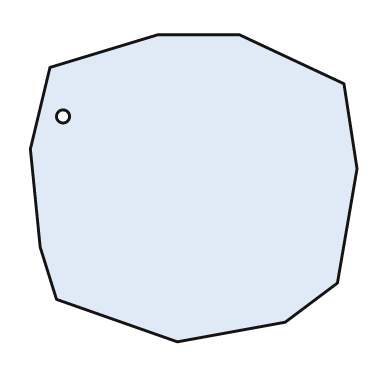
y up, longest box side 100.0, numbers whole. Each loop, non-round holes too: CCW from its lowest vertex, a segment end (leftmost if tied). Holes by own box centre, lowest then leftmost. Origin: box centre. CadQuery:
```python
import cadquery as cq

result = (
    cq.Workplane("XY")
    .moveTo(-5.0, -47.0)
    .lineTo(28.0, -41.0)
    .lineTo(44.0, -29.0)
    .lineTo(50.0, 6.0)
    .lineTo(46.0, 32.0)
    .lineTo(14.0, 47.0)
    .lineTo(-11.0, 47.0)
    .lineTo(-44.0, 37.0)
    .lineTo(-50.0, 12.0)
    .lineTo(-47.0, -18.0)
    .lineTo(-42.0, -34.0)
    .close()
    .moveTo(-40.0, 22.0)
    .circle(2.0)
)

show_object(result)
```